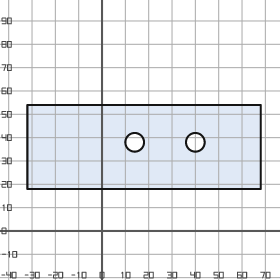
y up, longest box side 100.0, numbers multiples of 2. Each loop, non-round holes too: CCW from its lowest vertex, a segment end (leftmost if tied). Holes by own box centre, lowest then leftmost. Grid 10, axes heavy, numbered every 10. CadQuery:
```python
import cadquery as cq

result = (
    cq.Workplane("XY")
    .moveTo(-32.0, 18.0)
    .lineTo(68.0, 18.0)
    .lineTo(68.0, 54.0)
    .lineTo(-32.0, 54.0)
    .close()
    .moveTo(14.0, 38.0)
    .circle(4.0)
    .moveTo(40.0, 38.0)
    .circle(4.0)
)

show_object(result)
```